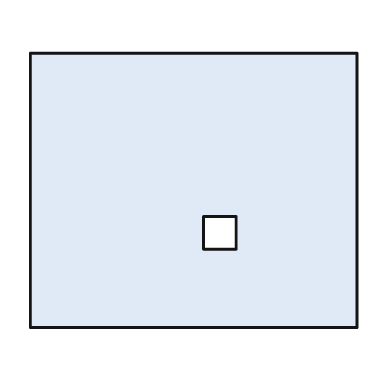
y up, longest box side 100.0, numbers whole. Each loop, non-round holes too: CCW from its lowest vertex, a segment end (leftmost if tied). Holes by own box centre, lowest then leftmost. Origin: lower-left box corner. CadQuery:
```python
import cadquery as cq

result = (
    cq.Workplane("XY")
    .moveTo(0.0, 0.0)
    .lineTo(100.0, 0.0)
    .lineTo(100.0, 84.0)
    .lineTo(0.0, 84.0)
    .close()
    .moveTo(53.0, 24.0)
    .lineTo(63.0, 24.0)
    .lineTo(63.0, 34.0)
    .lineTo(53.0, 34.0)
    .close()
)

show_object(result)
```